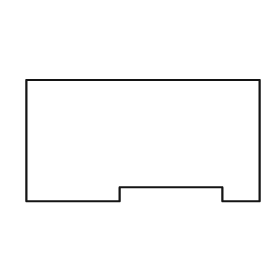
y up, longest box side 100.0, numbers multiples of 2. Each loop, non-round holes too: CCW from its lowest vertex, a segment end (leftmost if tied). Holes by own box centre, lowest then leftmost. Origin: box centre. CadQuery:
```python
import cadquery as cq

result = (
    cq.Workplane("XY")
    .moveTo(-50.0, -26.0)
    .lineTo(-10.0, -26.0)
    .lineTo(-10.0, -20.0)
    .lineTo(34.0, -20.0)
    .lineTo(34.0, -26.0)
    .lineTo(50.0, -26.0)
    .lineTo(50.0, 26.0)
    .lineTo(-50.0, 26.0)
    .close()
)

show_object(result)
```